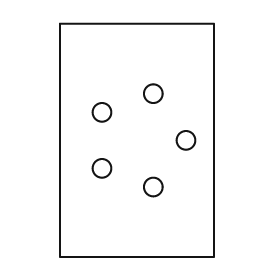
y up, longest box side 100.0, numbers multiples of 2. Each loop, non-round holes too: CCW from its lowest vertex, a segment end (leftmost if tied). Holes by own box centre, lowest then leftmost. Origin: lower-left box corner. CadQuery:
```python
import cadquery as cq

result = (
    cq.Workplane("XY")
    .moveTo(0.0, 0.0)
    .lineTo(66.0, 0.0)
    .lineTo(66.0, 100.0)
    .lineTo(0.0, 100.0)
    .close()
    .moveTo(40.0, 30.0)
    .circle(4.0)
    .moveTo(18.0, 38.0)
    .circle(4.0)
    .moveTo(54.0, 50.0)
    .circle(4.0)
    .moveTo(18.0, 62.0)
    .circle(4.0)
    .moveTo(40.0, 70.0)
    .circle(4.0)
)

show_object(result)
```